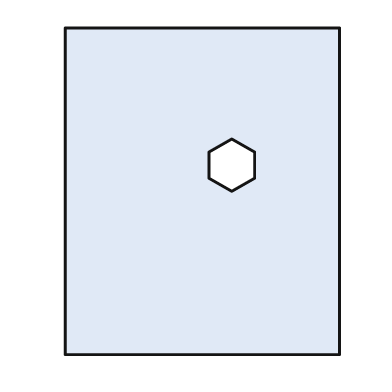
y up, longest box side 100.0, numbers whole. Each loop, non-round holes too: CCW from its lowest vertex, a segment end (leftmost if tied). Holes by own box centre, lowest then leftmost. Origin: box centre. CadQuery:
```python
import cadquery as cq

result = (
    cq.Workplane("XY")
    .moveTo(-42.0, -50.0)
    .lineTo(42.0, -50.0)
    .lineTo(42.0, 50.0)
    .lineTo(-42.0, 50.0)
    .close()
    .moveTo(9.0, 0.0)
    .lineTo(16.0, 4.0)
    .lineTo(16.0, 12.0)
    .lineTo(9.0, 16.0)
    .lineTo(2.0, 12.0)
    .lineTo(2.0, 4.0)
    .close()
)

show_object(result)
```